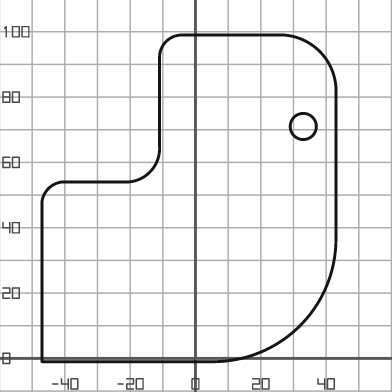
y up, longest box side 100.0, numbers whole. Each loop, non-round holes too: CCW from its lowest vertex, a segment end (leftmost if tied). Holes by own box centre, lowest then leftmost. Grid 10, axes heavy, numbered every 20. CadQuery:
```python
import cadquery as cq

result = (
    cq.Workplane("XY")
    .moveTo(-47.0, -1.0)
    .lineTo(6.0, -1.0)
    .threePointArc((32.0, 10.0), (43.0, 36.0))
    .lineTo(43.0, 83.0)
    .threePointArc((38.0, 94.0), (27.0, 99.0))
    .lineTo(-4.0, 99.0)
    .threePointArc((-9.0, 97.0), (-11.0, 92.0))
    .lineTo(-11.0, 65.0)
    .threePointArc((-14.0, 57.0), (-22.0, 54.0))
    .lineTo(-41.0, 54.0)
    .threePointArc((-45.0, 52.0), (-47.0, 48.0))
    .close()
    .moveTo(33.0, 71.0)
    .circle(4.0)
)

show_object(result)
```